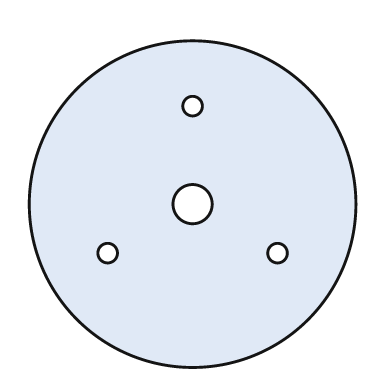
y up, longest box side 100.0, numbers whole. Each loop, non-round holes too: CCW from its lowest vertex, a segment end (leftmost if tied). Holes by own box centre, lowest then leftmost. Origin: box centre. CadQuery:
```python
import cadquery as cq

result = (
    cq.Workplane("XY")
    .moveTo(0.0, 0.0)
    .circle(50.0)
    .moveTo(-26.0, -15.0)
    .circle(3.0)
    .moveTo(26.0, -15.0)
    .circle(3.0)
    .moveTo(0.0, 0.0)
    .circle(6.0)
    .moveTo(0.0, 30.0)
    .circle(3.0)
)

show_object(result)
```